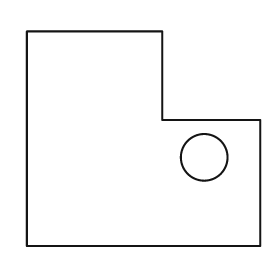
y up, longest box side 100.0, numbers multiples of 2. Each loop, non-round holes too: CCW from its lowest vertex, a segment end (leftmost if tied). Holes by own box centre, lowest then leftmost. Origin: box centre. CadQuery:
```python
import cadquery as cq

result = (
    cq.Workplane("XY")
    .moveTo(-50.0, -46.0)
    .lineTo(50.0, -46.0)
    .lineTo(50.0, 8.0)
    .lineTo(8.0, 8.0)
    .lineTo(8.0, 46.0)
    .lineTo(-50.0, 46.0)
    .close()
    .moveTo(26.0, -8.0)
    .circle(10.0)
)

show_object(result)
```